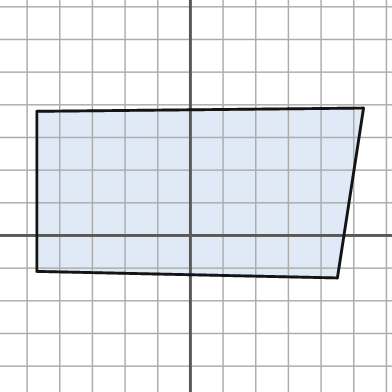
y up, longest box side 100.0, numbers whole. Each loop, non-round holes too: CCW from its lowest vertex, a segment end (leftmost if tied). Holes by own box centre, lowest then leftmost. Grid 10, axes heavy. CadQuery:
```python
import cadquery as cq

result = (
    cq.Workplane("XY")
    .moveTo(45.0, -13.0)
    .lineTo(53.0, 39.0)
    .lineTo(-47.0, 38.0)
    .lineTo(-47.0, -11.0)
    .close()
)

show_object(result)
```